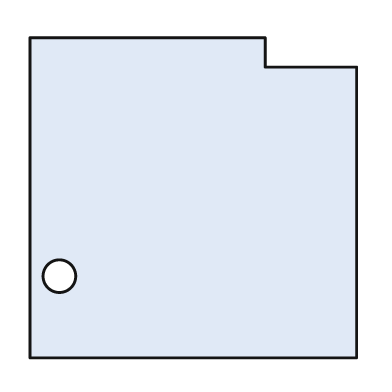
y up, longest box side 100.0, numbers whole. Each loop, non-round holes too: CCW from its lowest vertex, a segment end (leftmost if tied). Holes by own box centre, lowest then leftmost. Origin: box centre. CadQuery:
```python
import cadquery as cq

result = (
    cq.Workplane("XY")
    .moveTo(-50.0, -49.0)
    .lineTo(50.0, -49.0)
    .lineTo(50.0, 40.0)
    .lineTo(22.0, 40.0)
    .lineTo(22.0, 49.0)
    .lineTo(-50.0, 49.0)
    .close()
    .moveTo(-41.0, -24.0)
    .circle(5.0)
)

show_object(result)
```